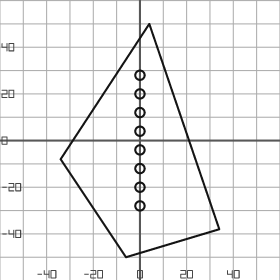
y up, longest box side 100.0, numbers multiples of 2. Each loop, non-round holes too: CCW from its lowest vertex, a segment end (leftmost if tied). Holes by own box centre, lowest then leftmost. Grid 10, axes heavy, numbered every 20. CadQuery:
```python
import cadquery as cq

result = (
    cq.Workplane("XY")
    .moveTo(-6.0, -50.0)
    .lineTo(34.0, -38.0)
    .lineTo(4.0, 50.0)
    .lineTo(-34.0, -8.0)
    .close()
    .moveTo(0.0, -28.0)
    .circle(2.0)
    .moveTo(0.0, -20.0)
    .circle(2.0)
    .moveTo(0.0, -12.0)
    .circle(2.0)
    .moveTo(0.0, -4.0)
    .circle(2.0)
    .moveTo(0.0, 4.0)
    .circle(2.0)
    .moveTo(0.0, 12.0)
    .circle(2.0)
    .moveTo(0.0, 20.0)
    .circle(2.0)
    .moveTo(0.0, 28.0)
    .circle(2.0)
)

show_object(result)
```